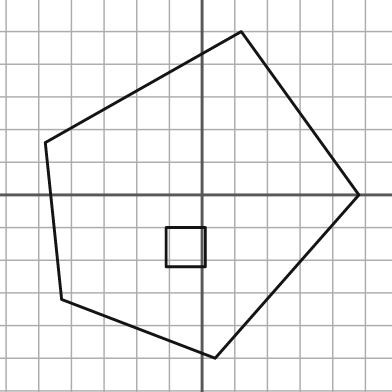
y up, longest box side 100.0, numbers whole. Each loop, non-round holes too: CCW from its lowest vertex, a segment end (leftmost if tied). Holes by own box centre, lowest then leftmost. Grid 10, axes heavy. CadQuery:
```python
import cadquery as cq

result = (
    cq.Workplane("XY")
    .moveTo(4.0, -50.0)
    .lineTo(48.0, 0.0)
    .lineTo(12.0, 50.0)
    .lineTo(-48.0, 16.0)
    .lineTo(-43.0, -32.0)
    .close()
    .moveTo(-11.0, -22.0)
    .lineTo(1.0, -22.0)
    .lineTo(1.0, -10.0)
    .lineTo(-11.0, -10.0)
    .close()
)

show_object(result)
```